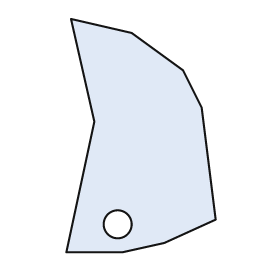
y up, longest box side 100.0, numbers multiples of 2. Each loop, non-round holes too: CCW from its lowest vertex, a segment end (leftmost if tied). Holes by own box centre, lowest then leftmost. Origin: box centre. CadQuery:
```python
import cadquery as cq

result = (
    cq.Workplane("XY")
    .moveTo(-32.0, -50.0)
    .lineTo(-8.0, -50.0)
    .lineTo(10.0, -46.0)
    .lineTo(32.0, -36.0)
    .lineTo(26.0, 12.0)
    .lineTo(18.0, 28.0)
    .lineTo(-4.0, 44.0)
    .lineTo(-30.0, 50.0)
    .lineTo(-20.0, 6.0)
    .close()
    .moveTo(-10.0, -38.0)
    .circle(6.0)
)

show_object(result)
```